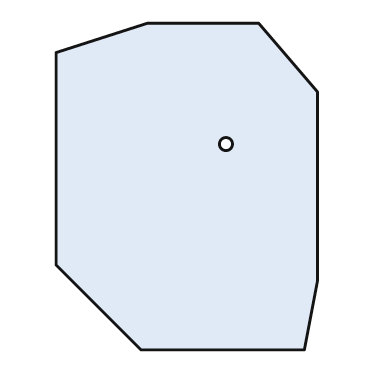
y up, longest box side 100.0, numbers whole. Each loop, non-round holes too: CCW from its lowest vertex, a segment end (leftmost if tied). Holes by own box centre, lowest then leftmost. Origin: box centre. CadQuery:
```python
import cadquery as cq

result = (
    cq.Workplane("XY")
    .moveTo(-14.0, -50.0)
    .lineTo(36.0, -50.0)
    .lineTo(40.0, -29.0)
    .lineTo(40.0, 29.0)
    .lineTo(22.0, 50.0)
    .lineTo(-12.0, 50.0)
    .lineTo(-40.0, 41.0)
    .lineTo(-40.0, -24.0)
    .close()
    .moveTo(12.0, 13.0)
    .circle(2.0)
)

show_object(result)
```